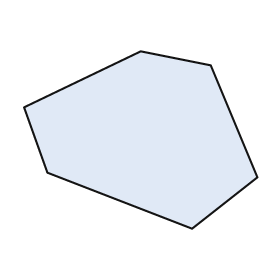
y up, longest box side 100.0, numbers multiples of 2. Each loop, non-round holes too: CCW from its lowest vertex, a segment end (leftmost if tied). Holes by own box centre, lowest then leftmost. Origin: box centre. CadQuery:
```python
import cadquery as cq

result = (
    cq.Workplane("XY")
    .moveTo(22.0, -38.0)
    .lineTo(50.0, -16.0)
    .lineTo(30.0, 32.0)
    .lineTo(0.0, 38.0)
    .lineTo(-50.0, 14.0)
    .lineTo(-40.0, -14.0)
    .close()
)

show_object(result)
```